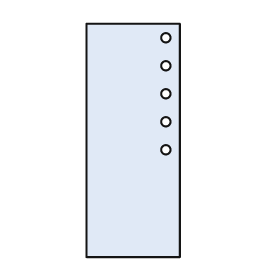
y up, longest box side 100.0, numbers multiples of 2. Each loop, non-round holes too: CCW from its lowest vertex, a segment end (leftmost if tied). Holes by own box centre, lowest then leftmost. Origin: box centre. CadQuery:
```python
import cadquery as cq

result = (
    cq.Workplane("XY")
    .moveTo(-20.0, -50.0)
    .lineTo(20.0, -50.0)
    .lineTo(20.0, 50.0)
    .lineTo(-20.0, 50.0)
    .close()
    .moveTo(14.0, -4.0)
    .circle(2.0)
    .moveTo(14.0, 8.0)
    .circle(2.0)
    .moveTo(14.0, 20.0)
    .circle(2.0)
    .moveTo(14.0, 32.0)
    .circle(2.0)
    .moveTo(14.0, 44.0)
    .circle(2.0)
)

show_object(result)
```